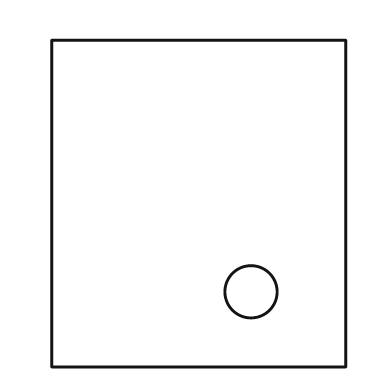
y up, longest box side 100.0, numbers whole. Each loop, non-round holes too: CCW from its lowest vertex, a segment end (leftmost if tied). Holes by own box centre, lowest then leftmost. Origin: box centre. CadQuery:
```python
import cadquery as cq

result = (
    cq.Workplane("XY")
    .moveTo(-45.0, -50.0)
    .lineTo(45.0, -50.0)
    .lineTo(45.0, 50.0)
    .lineTo(-45.0, 50.0)
    .close()
    .moveTo(16.0, -27.0)
    .circle(8.0)
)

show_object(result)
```